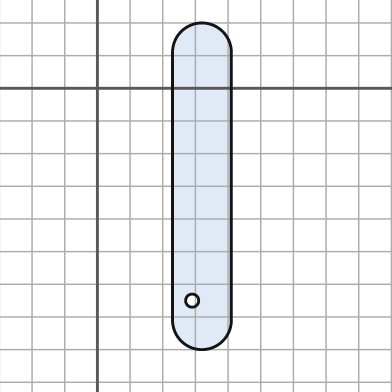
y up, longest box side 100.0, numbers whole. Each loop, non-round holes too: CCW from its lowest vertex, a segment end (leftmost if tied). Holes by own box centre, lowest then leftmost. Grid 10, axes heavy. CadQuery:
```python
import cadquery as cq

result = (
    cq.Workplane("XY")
    .moveTo(23.0, -71.0)
    .threePointArc((32.0, -80.0), (41.0, -71.0))
    .lineTo(41.0, 11.0)
    .threePointArc((32.0, 20.0), (23.0, 11.0))
    .close()
    .moveTo(29.0, -65.0)
    .circle(2.0)
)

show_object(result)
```